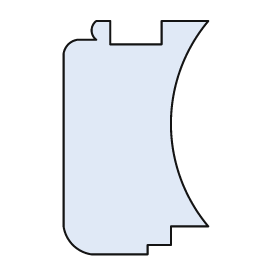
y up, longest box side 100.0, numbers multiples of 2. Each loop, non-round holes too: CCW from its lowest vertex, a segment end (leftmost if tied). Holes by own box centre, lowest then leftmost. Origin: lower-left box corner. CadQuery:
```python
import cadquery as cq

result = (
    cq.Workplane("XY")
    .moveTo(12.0, 0.0)
    .lineTo(36.0, 0.0)
    .lineTo(36.0, 4.0)
    .lineTo(46.0, 4.0)
    .lineTo(46.0, 12.0)
    .lineTo(62.0, 12.0)
    .threePointArc((46.0, 56.0), (62.0, 100.0))
    .lineTo(42.0, 100.0)
    .lineTo(42.0, 90.0)
    .lineTo(20.0, 90.0)
    .lineTo(20.0, 100.0)
    .lineTo(14.0, 100.0)
    .threePointArc((12.0, 96.0), (14.0, 92.0))
    .lineTo(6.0, 92.0)
    .threePointArc((2.0, 90.0), (0.0, 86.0))
    .lineTo(0.0, 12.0)
    .threePointArc((4.0, 4.0), (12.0, 0.0))
    .close()
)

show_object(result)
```